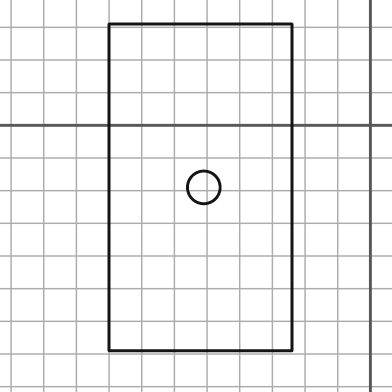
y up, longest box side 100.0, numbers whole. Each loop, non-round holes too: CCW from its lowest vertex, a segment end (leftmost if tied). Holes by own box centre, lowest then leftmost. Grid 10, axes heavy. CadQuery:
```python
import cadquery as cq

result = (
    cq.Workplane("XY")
    .moveTo(-80.0, -69.0)
    .lineTo(-24.0, -69.0)
    .lineTo(-24.0, 31.0)
    .lineTo(-80.0, 31.0)
    .close()
    .moveTo(-51.0, -19.0)
    .circle(5.0)
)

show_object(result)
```